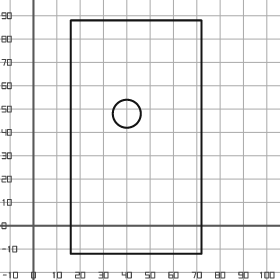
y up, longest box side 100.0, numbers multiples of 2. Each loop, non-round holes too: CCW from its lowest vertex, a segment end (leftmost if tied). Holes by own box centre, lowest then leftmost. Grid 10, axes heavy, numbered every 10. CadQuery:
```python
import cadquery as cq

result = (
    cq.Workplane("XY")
    .moveTo(16.0, -12.0)
    .lineTo(72.0, -12.0)
    .lineTo(72.0, 88.0)
    .lineTo(16.0, 88.0)
    .close()
    .moveTo(40.0, 48.0)
    .circle(6.0)
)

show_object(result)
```